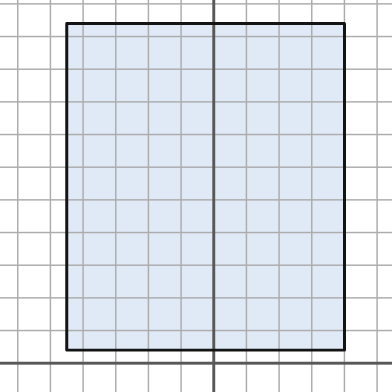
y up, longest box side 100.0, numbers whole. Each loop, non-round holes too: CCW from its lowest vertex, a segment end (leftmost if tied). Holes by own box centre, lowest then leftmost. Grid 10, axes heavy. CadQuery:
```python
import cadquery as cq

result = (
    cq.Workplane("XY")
    .moveTo(-45.0, 4.0)
    .lineTo(40.0, 4.0)
    .lineTo(40.0, 104.0)
    .lineTo(-45.0, 104.0)
    .close()
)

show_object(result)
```